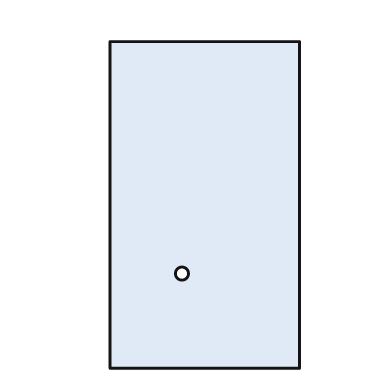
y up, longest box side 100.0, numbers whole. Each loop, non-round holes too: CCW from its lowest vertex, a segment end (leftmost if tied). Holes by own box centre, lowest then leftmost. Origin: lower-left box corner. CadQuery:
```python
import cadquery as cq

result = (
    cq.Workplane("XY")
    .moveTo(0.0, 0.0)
    .lineTo(58.0, 0.0)
    .lineTo(58.0, 100.0)
    .lineTo(0.0, 100.0)
    .close()
    .moveTo(22.0, 29.0)
    .circle(2.0)
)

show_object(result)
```